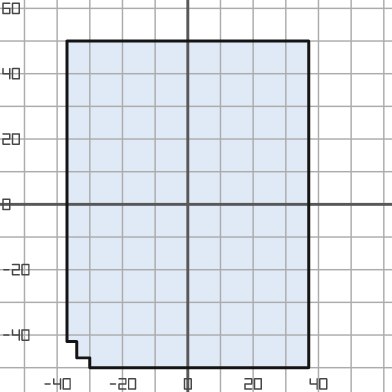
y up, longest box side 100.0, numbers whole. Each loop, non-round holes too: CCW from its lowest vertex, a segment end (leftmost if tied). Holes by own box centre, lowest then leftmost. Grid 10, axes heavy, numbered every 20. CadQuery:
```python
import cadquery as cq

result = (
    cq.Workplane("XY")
    .moveTo(-30.0, -50.0)
    .lineTo(37.0, -50.0)
    .lineTo(37.0, 50.0)
    .lineTo(-37.0, 50.0)
    .lineTo(-37.0, -42.0)
    .lineTo(-34.0, -42.0)
    .lineTo(-34.0, -47.0)
    .lineTo(-30.0, -47.0)
    .close()
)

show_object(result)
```